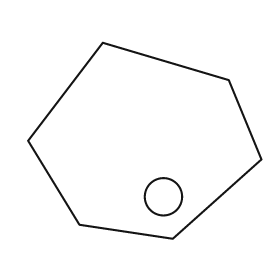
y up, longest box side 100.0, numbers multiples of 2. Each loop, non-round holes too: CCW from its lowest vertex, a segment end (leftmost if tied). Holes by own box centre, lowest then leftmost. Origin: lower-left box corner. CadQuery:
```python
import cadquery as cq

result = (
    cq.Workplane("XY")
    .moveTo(62.0, 0.0)
    .lineTo(100.0, 34.0)
    .lineTo(86.0, 68.0)
    .lineTo(32.0, 84.0)
    .lineTo(0.0, 42.0)
    .lineTo(22.0, 6.0)
    .close()
    .moveTo(58.0, 18.0)
    .circle(8.0)
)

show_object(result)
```